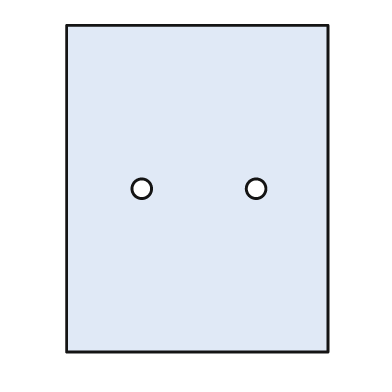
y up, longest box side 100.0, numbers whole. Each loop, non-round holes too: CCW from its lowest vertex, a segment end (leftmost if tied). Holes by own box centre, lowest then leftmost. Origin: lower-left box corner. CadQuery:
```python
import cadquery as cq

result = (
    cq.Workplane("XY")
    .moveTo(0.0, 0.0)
    .lineTo(80.0, 0.0)
    .lineTo(80.0, 100.0)
    .lineTo(0.0, 100.0)
    .close()
    .moveTo(23.0, 50.0)
    .circle(3.0)
    .moveTo(58.0, 50.0)
    .circle(3.0)
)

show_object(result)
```